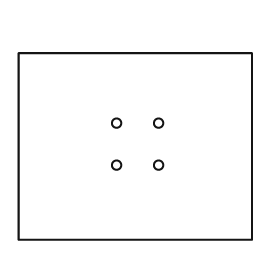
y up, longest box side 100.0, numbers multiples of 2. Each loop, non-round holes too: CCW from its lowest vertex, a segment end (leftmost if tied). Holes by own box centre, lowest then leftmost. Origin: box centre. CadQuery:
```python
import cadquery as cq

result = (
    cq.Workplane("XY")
    .moveTo(-50.0, -40.0)
    .lineTo(50.0, -40.0)
    .lineTo(50.0, 40.0)
    .lineTo(-50.0, 40.0)
    .close()
    .moveTo(-8.0, -8.0)
    .circle(2.0)
    .moveTo(10.0, -8.0)
    .circle(2.0)
    .moveTo(-8.0, 10.0)
    .circle(2.0)
    .moveTo(10.0, 10.0)
    .circle(2.0)
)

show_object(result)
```